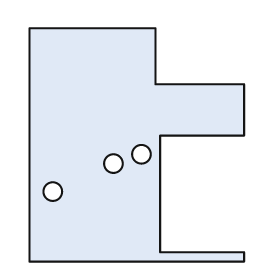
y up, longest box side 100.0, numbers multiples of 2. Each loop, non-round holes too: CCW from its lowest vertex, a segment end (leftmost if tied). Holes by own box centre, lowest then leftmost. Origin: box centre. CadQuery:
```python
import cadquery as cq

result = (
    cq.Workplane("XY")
    .moveTo(-46.0, -50.0)
    .lineTo(46.0, -50.0)
    .lineTo(46.0, -46.0)
    .lineTo(10.0, -46.0)
    .lineTo(10.0, 4.0)
    .lineTo(46.0, 4.0)
    .lineTo(46.0, 26.0)
    .lineTo(8.0, 26.0)
    .lineTo(8.0, 50.0)
    .lineTo(-46.0, 50.0)
    .close()
    .moveTo(-36.0, -20.0)
    .circle(4.0)
    .moveTo(-10.0, -8.0)
    .circle(4.0)
    .moveTo(2.0, -4.0)
    .circle(4.0)
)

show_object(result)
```